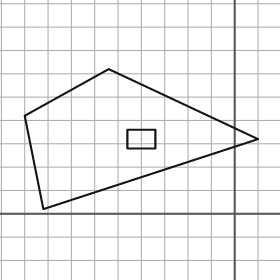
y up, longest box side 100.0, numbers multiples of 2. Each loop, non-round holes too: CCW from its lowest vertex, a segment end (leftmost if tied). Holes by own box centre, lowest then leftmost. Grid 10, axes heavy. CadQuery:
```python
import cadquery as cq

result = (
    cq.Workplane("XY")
    .moveTo(-82.0, 2.0)
    .lineTo(10.0, 32.0)
    .lineTo(-54.0, 62.0)
    .lineTo(-90.0, 42.0)
    .close()
    .moveTo(-46.0, 28.0)
    .lineTo(-34.0, 28.0)
    .lineTo(-34.0, 36.0)
    .lineTo(-46.0, 36.0)
    .close()
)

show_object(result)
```